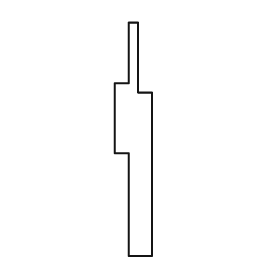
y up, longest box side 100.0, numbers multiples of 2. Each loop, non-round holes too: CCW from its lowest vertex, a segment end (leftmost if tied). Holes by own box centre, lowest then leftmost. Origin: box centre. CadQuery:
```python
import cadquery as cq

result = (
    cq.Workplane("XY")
    .moveTo(-2.0, -50.0)
    .lineTo(8.0, -50.0)
    .lineTo(8.0, 20.0)
    .lineTo(2.0, 20.0)
    .lineTo(2.0, 50.0)
    .lineTo(-2.0, 50.0)
    .lineTo(-2.0, 24.0)
    .lineTo(-8.0, 24.0)
    .lineTo(-8.0, -6.0)
    .lineTo(-2.0, -6.0)
    .close()
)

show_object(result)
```